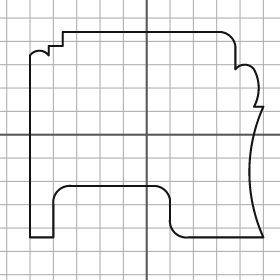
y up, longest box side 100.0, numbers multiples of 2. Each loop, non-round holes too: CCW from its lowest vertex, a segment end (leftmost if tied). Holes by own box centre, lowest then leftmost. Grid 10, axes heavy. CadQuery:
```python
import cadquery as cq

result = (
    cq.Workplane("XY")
    .moveTo(-50.0, -44.0)
    .lineTo(-40.0, -44.0)
    .lineTo(-40.0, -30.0)
    .threePointArc((-38.0, -24.0), (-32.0, -22.0))
    .lineTo(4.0, -22.0)
    .threePointArc((8.0, -24.0), (10.0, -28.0))
    .lineTo(10.0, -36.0)
    .threePointArc((12.0, -42.0), (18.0, -44.0))
    .lineTo(50.0, -44.0)
    .threePointArc((44.0, -16.0), (50.0, 12.0))
    .lineTo(46.0, 12.0)
    .threePointArc((48.0, 20.0), (46.0, 28.0))
    .threePointArc((42.0, 30.0), (38.0, 28.0))
    .lineTo(38.0, 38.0)
    .threePointArc((36.0, 42.0), (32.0, 44.0))
    .lineTo(-36.0, 44.0)
    .lineTo(-36.0, 38.0)
    .lineTo(-42.0, 38.0)
    .lineTo(-42.0, 34.0)
    .threePointArc((-46.0, 36.0), (-50.0, 34.0))
    .close()
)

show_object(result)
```